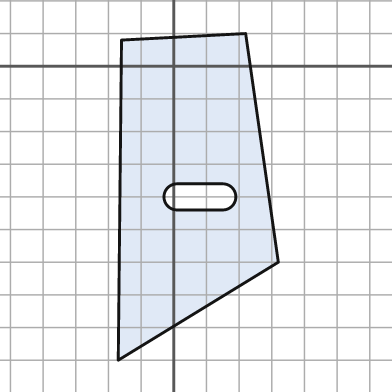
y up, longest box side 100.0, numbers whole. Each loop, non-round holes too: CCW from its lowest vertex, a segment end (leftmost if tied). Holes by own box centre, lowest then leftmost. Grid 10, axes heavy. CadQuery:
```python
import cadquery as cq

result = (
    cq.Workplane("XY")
    .moveTo(-17.0, -90.0)
    .lineTo(32.0, -60.0)
    .lineTo(22.0, 10.0)
    .lineTo(-16.0, 8.0)
    .close()
    .moveTo(1.0, -44.0)
    .lineTo(15.0, -44.0)
    .threePointArc((19.0, -40.0), (15.0, -36.0))
    .lineTo(1.0, -36.0)
    .threePointArc((-3.0, -40.0), (1.0, -44.0))
    .close()
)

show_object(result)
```